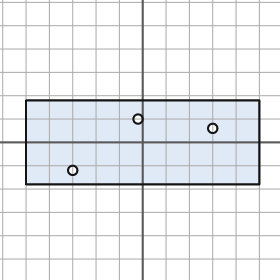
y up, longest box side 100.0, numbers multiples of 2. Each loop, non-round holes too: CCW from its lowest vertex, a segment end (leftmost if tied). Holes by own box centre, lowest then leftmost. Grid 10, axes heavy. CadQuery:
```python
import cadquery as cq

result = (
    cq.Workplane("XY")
    .moveTo(-50.0, -18.0)
    .lineTo(50.0, -18.0)
    .lineTo(50.0, 18.0)
    .lineTo(-50.0, 18.0)
    .close()
    .moveTo(-30.0, -12.0)
    .circle(2.0)
    .moveTo(30.0, 6.0)
    .circle(2.0)
    .moveTo(-2.0, 10.0)
    .circle(2.0)
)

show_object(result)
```